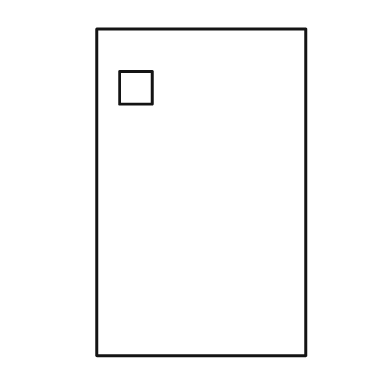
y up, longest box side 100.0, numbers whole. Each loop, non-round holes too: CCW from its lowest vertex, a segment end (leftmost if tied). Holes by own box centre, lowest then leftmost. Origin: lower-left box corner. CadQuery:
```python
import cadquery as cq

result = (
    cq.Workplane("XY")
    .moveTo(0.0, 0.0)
    .lineTo(64.0, 0.0)
    .lineTo(64.0, 100.0)
    .lineTo(0.0, 100.0)
    .close()
    .moveTo(7.0, 77.0)
    .lineTo(17.0, 77.0)
    .lineTo(17.0, 87.0)
    .lineTo(7.0, 87.0)
    .close()
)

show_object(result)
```